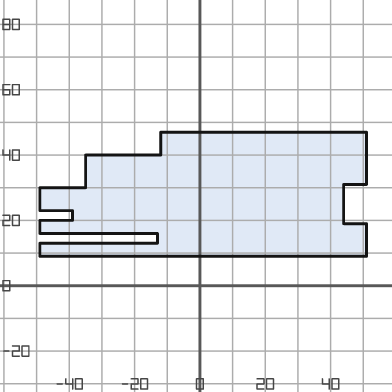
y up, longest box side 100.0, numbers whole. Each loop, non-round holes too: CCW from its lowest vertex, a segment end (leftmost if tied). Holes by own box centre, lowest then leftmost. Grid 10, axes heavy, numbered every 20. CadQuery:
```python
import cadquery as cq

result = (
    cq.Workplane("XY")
    .moveTo(-49.0, 9.0)
    .lineTo(51.0, 9.0)
    .lineTo(51.0, 19.0)
    .lineTo(44.0, 19.0)
    .lineTo(44.0, 31.0)
    .lineTo(51.0, 31.0)
    .lineTo(51.0, 47.0)
    .lineTo(-12.0, 47.0)
    .lineTo(-12.0, 40.0)
    .lineTo(-35.0, 40.0)
    .lineTo(-35.0, 30.0)
    .lineTo(-49.0, 30.0)
    .lineTo(-49.0, 23.0)
    .lineTo(-39.0, 23.0)
    .lineTo(-39.0, 20.0)
    .lineTo(-49.0, 20.0)
    .lineTo(-49.0, 16.0)
    .lineTo(-13.0, 16.0)
    .lineTo(-13.0, 13.0)
    .lineTo(-49.0, 13.0)
    .close()
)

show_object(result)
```